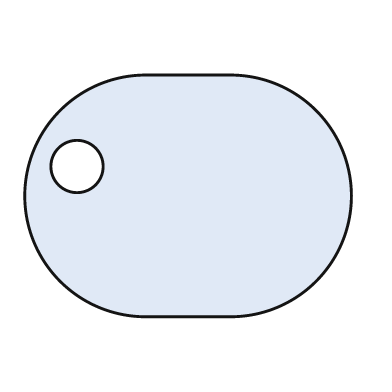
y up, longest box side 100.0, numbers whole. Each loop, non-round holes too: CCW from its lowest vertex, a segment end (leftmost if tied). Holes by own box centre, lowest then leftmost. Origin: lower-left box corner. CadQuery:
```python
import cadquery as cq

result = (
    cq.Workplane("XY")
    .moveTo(37.0, 0.0)
    .lineTo(63.0, 0.0)
    .threePointArc((100.0, 37.0), (63.0, 74.0))
    .lineTo(37.0, 74.0)
    .threePointArc((0.0, 37.0), (37.0, 0.0))
    .close()
    .moveTo(16.0, 46.0)
    .circle(8.0)
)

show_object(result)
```